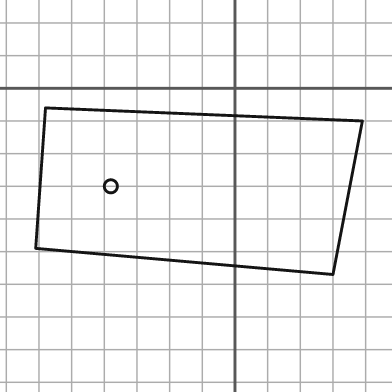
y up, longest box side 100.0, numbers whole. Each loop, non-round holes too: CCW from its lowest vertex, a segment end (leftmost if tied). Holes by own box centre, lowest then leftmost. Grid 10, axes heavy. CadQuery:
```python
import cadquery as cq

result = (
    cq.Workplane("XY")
    .moveTo(30.0, -57.0)
    .lineTo(39.0, -10.0)
    .lineTo(-58.0, -6.0)
    .lineTo(-61.0, -49.0)
    .close()
    .moveTo(-38.0, -30.0)
    .circle(2.0)
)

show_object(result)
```